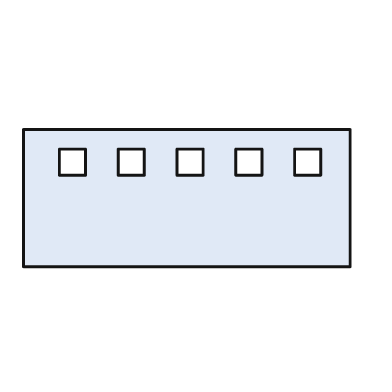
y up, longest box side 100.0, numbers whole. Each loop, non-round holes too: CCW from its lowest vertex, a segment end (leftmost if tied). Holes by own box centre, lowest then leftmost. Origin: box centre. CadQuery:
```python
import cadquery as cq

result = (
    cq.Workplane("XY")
    .moveTo(-50.0, -21.0)
    .lineTo(50.0, -21.0)
    .lineTo(50.0, 21.0)
    .lineTo(-50.0, 21.0)
    .close()
    .moveTo(-39.0, 7.0)
    .lineTo(-31.0, 7.0)
    .lineTo(-31.0, 15.0)
    .lineTo(-39.0, 15.0)
    .close()
    .moveTo(-21.0, 7.0)
    .lineTo(-13.0, 7.0)
    .lineTo(-13.0, 15.0)
    .lineTo(-21.0, 15.0)
    .close()
    .moveTo(-3.0, 7.0)
    .lineTo(5.0, 7.0)
    .lineTo(5.0, 15.0)
    .lineTo(-3.0, 15.0)
    .close()
    .moveTo(15.0, 7.0)
    .lineTo(23.0, 7.0)
    .lineTo(23.0, 15.0)
    .lineTo(15.0, 15.0)
    .close()
    .moveTo(33.0, 7.0)
    .lineTo(41.0, 7.0)
    .lineTo(41.0, 15.0)
    .lineTo(33.0, 15.0)
    .close()
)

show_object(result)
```